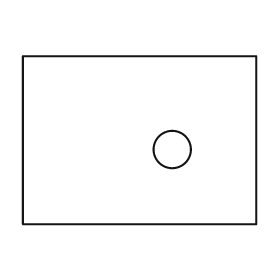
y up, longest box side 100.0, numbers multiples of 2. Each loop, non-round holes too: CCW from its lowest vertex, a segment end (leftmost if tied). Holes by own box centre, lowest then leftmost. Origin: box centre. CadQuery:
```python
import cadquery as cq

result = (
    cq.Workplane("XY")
    .moveTo(-50.0, -36.0)
    .lineTo(50.0, -36.0)
    .lineTo(50.0, 36.0)
    .lineTo(-50.0, 36.0)
    .close()
    .moveTo(14.0, -4.0)
    .circle(8.0)
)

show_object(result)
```